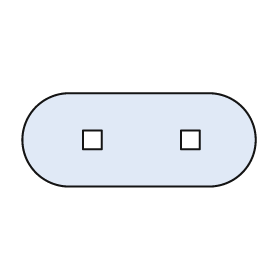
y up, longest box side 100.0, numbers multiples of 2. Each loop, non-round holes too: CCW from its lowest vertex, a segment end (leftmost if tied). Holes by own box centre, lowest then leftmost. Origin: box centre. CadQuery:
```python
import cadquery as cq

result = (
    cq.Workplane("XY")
    .moveTo(-30.0, -20.0)
    .lineTo(30.0, -20.0)
    .threePointArc((50.0, 0.0), (30.0, 20.0))
    .lineTo(-30.0, 20.0)
    .threePointArc((-50.0, 0.0), (-30.0, -20.0))
    .close()
    .moveTo(-24.0, -4.0)
    .lineTo(-16.0, -4.0)
    .lineTo(-16.0, 4.0)
    .lineTo(-24.0, 4.0)
    .close()
    .moveTo(18.0, -4.0)
    .lineTo(26.0, -4.0)
    .lineTo(26.0, 4.0)
    .lineTo(18.0, 4.0)
    .close()
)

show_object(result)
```